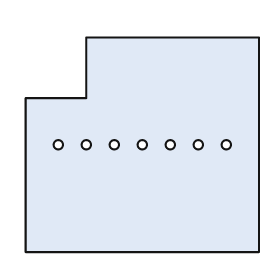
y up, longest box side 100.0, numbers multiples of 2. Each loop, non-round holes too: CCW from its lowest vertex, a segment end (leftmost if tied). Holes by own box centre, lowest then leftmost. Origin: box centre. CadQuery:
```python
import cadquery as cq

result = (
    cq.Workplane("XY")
    .moveTo(-50.0, -46.0)
    .lineTo(50.0, -46.0)
    .lineTo(50.0, 46.0)
    .lineTo(-24.0, 46.0)
    .lineTo(-24.0, 20.0)
    .lineTo(-50.0, 20.0)
    .close()
    .moveTo(-36.0, 0.0)
    .circle(2.0)
    .moveTo(-24.0, 0.0)
    .circle(2.0)
    .moveTo(-12.0, 0.0)
    .circle(2.0)
    .moveTo(0.0, 0.0)
    .circle(2.0)
    .moveTo(12.0, 0.0)
    .circle(2.0)
    .moveTo(24.0, 0.0)
    .circle(2.0)
    .moveTo(36.0, 0.0)
    .circle(2.0)
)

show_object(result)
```